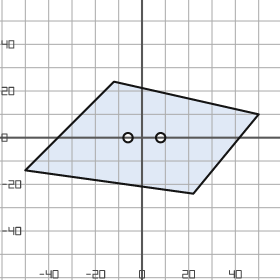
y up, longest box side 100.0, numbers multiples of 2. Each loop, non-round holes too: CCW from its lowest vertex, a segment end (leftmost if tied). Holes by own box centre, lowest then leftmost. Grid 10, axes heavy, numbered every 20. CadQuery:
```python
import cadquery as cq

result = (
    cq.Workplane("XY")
    .moveTo(22.0, -24.0)
    .lineTo(50.0, 10.0)
    .lineTo(-12.0, 24.0)
    .lineTo(-50.0, -14.0)
    .close()
    .moveTo(-6.0, 0.0)
    .circle(2.0)
    .moveTo(8.0, 0.0)
    .circle(2.0)
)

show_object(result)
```